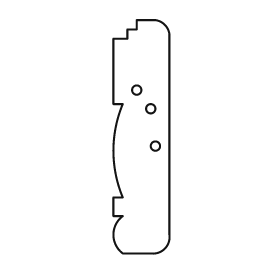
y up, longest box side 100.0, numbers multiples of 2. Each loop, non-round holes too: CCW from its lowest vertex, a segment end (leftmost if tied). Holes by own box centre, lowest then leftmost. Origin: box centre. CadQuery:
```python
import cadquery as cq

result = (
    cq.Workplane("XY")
    .moveTo(-8.0, -50.0)
    .lineTo(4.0, -50.0)
    .threePointArc((10.0, -48.0), (12.0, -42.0))
    .lineTo(12.0, 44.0)
    .threePointArc((10.0, 48.0), (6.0, 50.0))
    .lineTo(-2.0, 50.0)
    .lineTo(-2.0, 46.0)
    .lineTo(-6.0, 46.0)
    .lineTo(-6.0, 42.0)
    .lineTo(-12.0, 42.0)
    .lineTo(-12.0, 14.0)
    .lineTo(-8.0, 14.0)
    .threePointArc((-12.0, -6.0), (-8.0, -26.0))
    .lineTo(-12.0, -26.0)
    .lineTo(-12.0, -34.0)
    .lineTo(-8.0, -34.0)
    .threePointArc((-12.0, -42.0), (-8.0, -50.0))
    .close()
    .moveTo(6.0, -4.0)
    .circle(2.0)
    .moveTo(4.0, 12.0)
    .circle(2.0)
    .moveTo(-2.0, 20.0)
    .circle(2.0)
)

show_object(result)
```